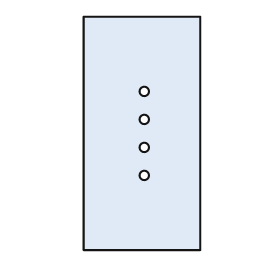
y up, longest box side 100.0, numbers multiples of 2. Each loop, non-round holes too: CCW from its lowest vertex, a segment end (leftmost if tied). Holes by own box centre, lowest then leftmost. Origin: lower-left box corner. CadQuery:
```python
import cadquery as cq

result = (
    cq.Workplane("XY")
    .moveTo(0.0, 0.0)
    .lineTo(50.0, 0.0)
    .lineTo(50.0, 100.0)
    .lineTo(0.0, 100.0)
    .close()
    .moveTo(26.0, 32.0)
    .circle(2.0)
    .moveTo(26.0, 44.0)
    .circle(2.0)
    .moveTo(26.0, 56.0)
    .circle(2.0)
    .moveTo(26.0, 68.0)
    .circle(2.0)
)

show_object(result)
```